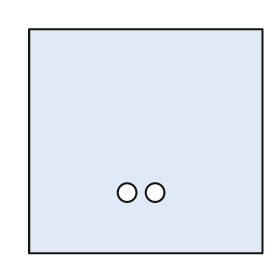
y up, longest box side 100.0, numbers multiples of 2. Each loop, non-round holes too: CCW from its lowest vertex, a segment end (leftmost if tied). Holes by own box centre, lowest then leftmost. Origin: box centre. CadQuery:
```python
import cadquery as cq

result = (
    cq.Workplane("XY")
    .moveTo(-50.0, -48.0)
    .lineTo(50.0, -48.0)
    .lineTo(50.0, 48.0)
    .lineTo(-50.0, 48.0)
    .close()
    .moveTo(-8.0, -22.0)
    .circle(4.0)
    .moveTo(4.0, -22.0)
    .circle(4.0)
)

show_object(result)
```